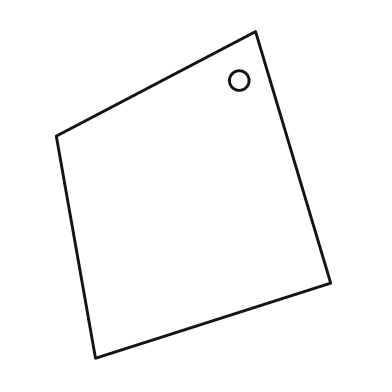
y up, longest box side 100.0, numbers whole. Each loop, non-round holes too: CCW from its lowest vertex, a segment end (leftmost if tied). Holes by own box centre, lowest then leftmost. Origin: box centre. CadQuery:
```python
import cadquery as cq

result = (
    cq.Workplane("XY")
    .moveTo(-30.0, -50.0)
    .lineTo(42.0, -27.0)
    .lineTo(19.0, 50.0)
    .lineTo(-42.0, 18.0)
    .close()
    .moveTo(14.0, 35.0)
    .circle(3.0)
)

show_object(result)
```